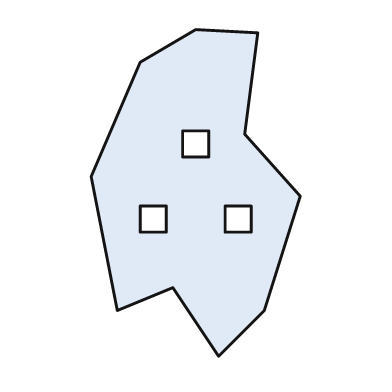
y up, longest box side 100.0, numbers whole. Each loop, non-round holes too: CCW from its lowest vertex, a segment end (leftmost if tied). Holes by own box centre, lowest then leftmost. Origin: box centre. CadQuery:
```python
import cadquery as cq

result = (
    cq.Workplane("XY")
    .moveTo(7.0, -50.0)
    .lineTo(21.0, -36.0)
    .lineTo(32.0, -1.0)
    .lineTo(15.0, 18.0)
    .lineTo(19.0, 49.0)
    .lineTo(0.0, 50.0)
    .lineTo(-17.0, 40.0)
    .lineTo(-32.0, 5.0)
    .lineTo(-24.0, -36.0)
    .lineTo(-7.0, -29.0)
    .close()
    .moveTo(-17.0, -12.0)
    .lineTo(-9.0, -12.0)
    .lineTo(-9.0, -4.0)
    .lineTo(-17.0, -4.0)
    .close()
    .moveTo(9.0, -12.0)
    .lineTo(17.0, -12.0)
    .lineTo(17.0, -4.0)
    .lineTo(9.0, -4.0)
    .close()
    .moveTo(-4.0, 11.0)
    .lineTo(4.0, 11.0)
    .lineTo(4.0, 19.0)
    .lineTo(-4.0, 19.0)
    .close()
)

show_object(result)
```